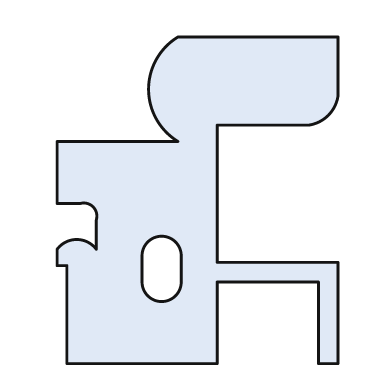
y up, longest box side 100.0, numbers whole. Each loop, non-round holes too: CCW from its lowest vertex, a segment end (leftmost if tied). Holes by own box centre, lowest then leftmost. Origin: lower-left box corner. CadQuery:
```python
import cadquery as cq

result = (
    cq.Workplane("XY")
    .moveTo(3.0, 0.0)
    .lineTo(49.0, 0.0)
    .lineTo(49.0, 25.0)
    .lineTo(80.0, 25.0)
    .lineTo(80.0, 0.0)
    .lineTo(86.0, 0.0)
    .lineTo(86.0, 31.0)
    .lineTo(49.0, 31.0)
    .lineTo(49.0, 73.0)
    .lineTo(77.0, 73.0)
    .threePointArc((83.0, 76.0), (86.0, 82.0))
    .lineTo(86.0, 100.0)
    .lineTo(37.0, 100.0)
    .threePointArc((28.0, 84.0), (37.0, 68.0))
    .lineTo(0.0, 68.0)
    .lineTo(0.0, 49.0)
    .lineTo(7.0, 49.0)
    .threePointArc((11.0, 48.0), (12.0, 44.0))
    .lineTo(12.0, 35.0)
    .threePointArc((6.0, 38.0), (0.0, 35.0))
    .lineTo(0.0, 30.0)
    .lineTo(3.0, 30.0)
    .close()
    .moveTo(26.0, 25.0)
    .threePointArc((32.0, 19.0), (38.0, 25.0))
    .lineTo(38.0, 33.0)
    .threePointArc((32.0, 39.0), (26.0, 33.0))
    .close()
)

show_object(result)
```